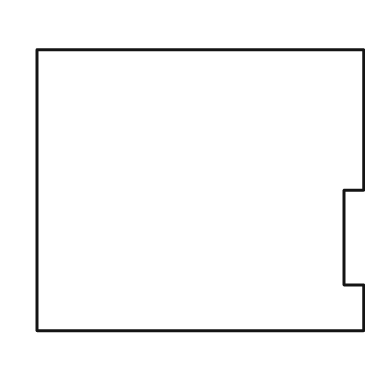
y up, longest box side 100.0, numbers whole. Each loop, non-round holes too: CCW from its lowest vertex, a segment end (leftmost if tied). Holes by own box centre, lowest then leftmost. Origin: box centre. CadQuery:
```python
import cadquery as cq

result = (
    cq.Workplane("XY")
    .moveTo(-50.0, -43.0)
    .lineTo(50.0, -43.0)
    .lineTo(50.0, -29.0)
    .lineTo(44.0, -29.0)
    .lineTo(44.0, 0.0)
    .lineTo(50.0, 0.0)
    .lineTo(50.0, 43.0)
    .lineTo(-50.0, 43.0)
    .close()
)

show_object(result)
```